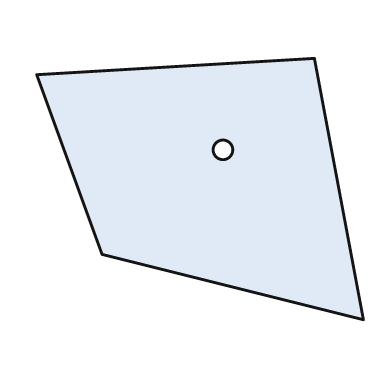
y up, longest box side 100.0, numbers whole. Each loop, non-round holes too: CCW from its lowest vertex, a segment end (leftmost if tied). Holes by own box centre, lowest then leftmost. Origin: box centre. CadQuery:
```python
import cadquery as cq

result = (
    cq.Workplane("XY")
    .moveTo(50.0, -40.0)
    .lineTo(35.0, 40.0)
    .lineTo(-50.0, 35.0)
    .lineTo(-30.0, -20.0)
    .close()
    .moveTo(7.0, 12.0)
    .circle(3.0)
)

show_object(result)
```